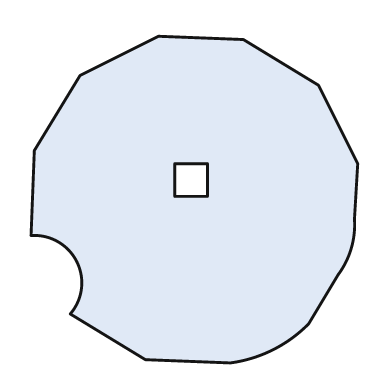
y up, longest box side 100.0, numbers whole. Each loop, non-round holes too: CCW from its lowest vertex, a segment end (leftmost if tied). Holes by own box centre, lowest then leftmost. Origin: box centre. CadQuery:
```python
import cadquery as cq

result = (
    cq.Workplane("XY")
    .moveTo(11.0, -50.0)
    .threePointArc((24.0, -46.0), (35.0, -38.0))
    .lineTo(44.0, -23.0)
    .threePointArc((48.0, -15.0), (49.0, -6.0))
    .lineTo(50.0, 11.0)
    .lineTo(38.0, 35.0)
    .lineTo(15.0, 49.0)
    .lineTo(-11.0, 50.0)
    .lineTo(-35.0, 38.0)
    .lineTo(-49.0, 15.0)
    .lineTo(-50.0, -11.0)
    .threePointArc((-36.0, -19.0), (-38.0, -35.0))
    .lineTo(-15.0, -49.0)
    .close()
    .moveTo(-6.0, 1.0)
    .lineTo(4.0, 1.0)
    .lineTo(4.0, 11.0)
    .lineTo(-6.0, 11.0)
    .close()
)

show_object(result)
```